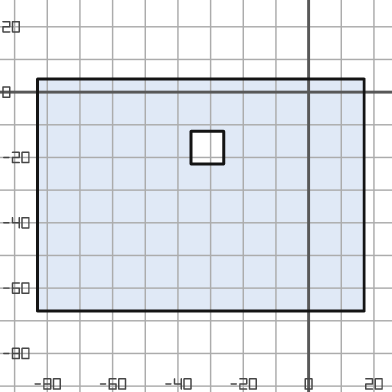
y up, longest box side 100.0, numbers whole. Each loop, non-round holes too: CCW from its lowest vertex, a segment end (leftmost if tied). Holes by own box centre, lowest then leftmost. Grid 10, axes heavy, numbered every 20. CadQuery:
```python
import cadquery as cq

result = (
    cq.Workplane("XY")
    .moveTo(-83.0, -67.0)
    .lineTo(17.0, -67.0)
    .lineTo(17.0, 4.0)
    .lineTo(-83.0, 4.0)
    .close()
    .moveTo(-36.0, -22.0)
    .lineTo(-26.0, -22.0)
    .lineTo(-26.0, -12.0)
    .lineTo(-36.0, -12.0)
    .close()
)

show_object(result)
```